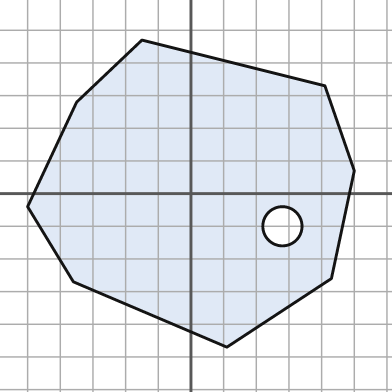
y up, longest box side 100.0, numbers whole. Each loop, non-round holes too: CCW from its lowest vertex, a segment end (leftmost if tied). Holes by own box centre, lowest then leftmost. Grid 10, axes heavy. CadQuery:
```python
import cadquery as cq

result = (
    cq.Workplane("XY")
    .moveTo(11.0, -47.0)
    .lineTo(43.0, -26.0)
    .lineTo(50.0, 7.0)
    .lineTo(41.0, 33.0)
    .lineTo(-15.0, 47.0)
    .lineTo(-35.0, 28.0)
    .lineTo(-50.0, -4.0)
    .lineTo(-36.0, -27.0)
    .close()
    .moveTo(28.0, -10.0)
    .circle(6.0)
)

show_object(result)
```